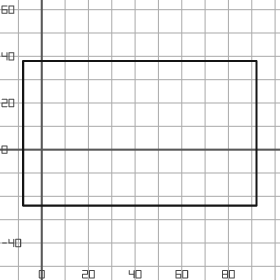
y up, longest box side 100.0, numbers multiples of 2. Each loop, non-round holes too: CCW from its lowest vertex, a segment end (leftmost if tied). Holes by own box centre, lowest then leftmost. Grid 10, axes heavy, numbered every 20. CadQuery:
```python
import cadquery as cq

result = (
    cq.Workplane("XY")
    .moveTo(-8.0, -24.0)
    .lineTo(92.0, -24.0)
    .lineTo(92.0, 38.0)
    .lineTo(-8.0, 38.0)
    .close()
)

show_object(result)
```